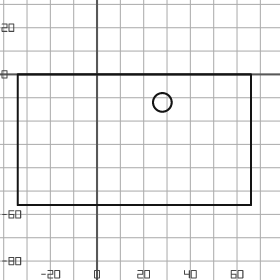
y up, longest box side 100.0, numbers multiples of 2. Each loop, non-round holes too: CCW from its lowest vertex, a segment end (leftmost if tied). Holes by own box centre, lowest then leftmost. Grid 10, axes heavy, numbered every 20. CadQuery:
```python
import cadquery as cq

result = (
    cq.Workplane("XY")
    .moveTo(-34.0, -56.0)
    .lineTo(66.0, -56.0)
    .lineTo(66.0, 0.0)
    .lineTo(-34.0, 0.0)
    .close()
    .moveTo(28.0, -12.0)
    .circle(4.0)
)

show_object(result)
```